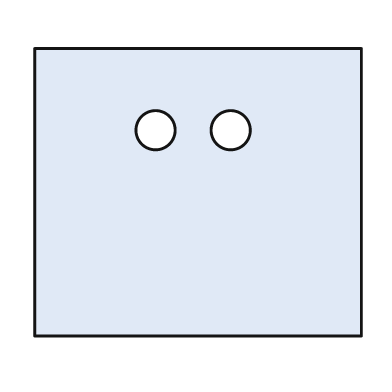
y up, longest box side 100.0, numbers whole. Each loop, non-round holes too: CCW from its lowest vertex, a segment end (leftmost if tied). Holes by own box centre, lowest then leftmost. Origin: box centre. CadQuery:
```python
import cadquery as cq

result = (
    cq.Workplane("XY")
    .moveTo(-50.0, -44.0)
    .lineTo(50.0, -44.0)
    .lineTo(50.0, 44.0)
    .lineTo(-50.0, 44.0)
    .close()
    .moveTo(-13.0, 19.0)
    .circle(6.0)
    .moveTo(10.0, 19.0)
    .circle(6.0)
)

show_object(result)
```